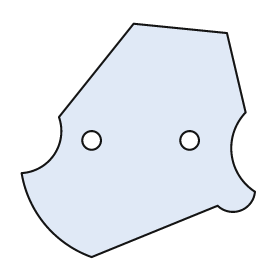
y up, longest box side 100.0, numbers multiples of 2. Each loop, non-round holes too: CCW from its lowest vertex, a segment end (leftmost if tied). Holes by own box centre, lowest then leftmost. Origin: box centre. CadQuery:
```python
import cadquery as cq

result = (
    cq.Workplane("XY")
    .moveTo(-20.0, -50.0)
    .lineTo(34.0, -28.0)
    .threePointArc((44.0, -30.0), (50.0, -22.0))
    .threePointArc((40.0, -6.0), (46.0, 12.0))
    .lineTo(38.0, 46.0)
    .lineTo(-2.0, 50.0)
    .lineTo(-34.0, 10.0)
    .threePointArc((-36.0, -6.0), (-50.0, -14.0))
    .threePointArc((-40.0, -36.0), (-20.0, -50.0))
    .close()
    .moveTo(-20.0, 0.0)
    .circle(4.0)
    .moveTo(22.0, 0.0)
    .circle(4.0)
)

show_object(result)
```